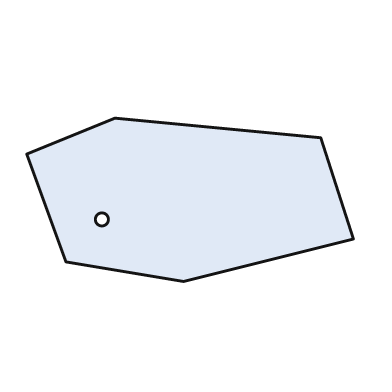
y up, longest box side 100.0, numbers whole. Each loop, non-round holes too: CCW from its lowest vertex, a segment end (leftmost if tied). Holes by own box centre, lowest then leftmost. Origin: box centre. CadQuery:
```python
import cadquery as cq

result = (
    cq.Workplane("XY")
    .moveTo(-2.0, -25.0)
    .lineTo(50.0, -12.0)
    .lineTo(40.0, 19.0)
    .lineTo(-23.0, 25.0)
    .lineTo(-50.0, 14.0)
    .lineTo(-38.0, -19.0)
    .close()
    .moveTo(-27.0, -6.0)
    .circle(2.0)
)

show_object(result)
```